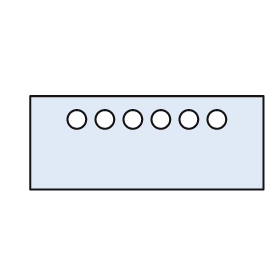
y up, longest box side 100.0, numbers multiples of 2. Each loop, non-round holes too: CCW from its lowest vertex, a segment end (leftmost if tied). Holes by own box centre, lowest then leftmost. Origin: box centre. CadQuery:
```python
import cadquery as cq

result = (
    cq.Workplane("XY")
    .moveTo(-50.0, -20.0)
    .lineTo(50.0, -20.0)
    .lineTo(50.0, 20.0)
    .lineTo(-50.0, 20.0)
    .close()
    .moveTo(-30.0, 10.0)
    .circle(4.0)
    .moveTo(-18.0, 10.0)
    .circle(4.0)
    .moveTo(-6.0, 10.0)
    .circle(4.0)
    .moveTo(6.0, 10.0)
    .circle(4.0)
    .moveTo(18.0, 10.0)
    .circle(4.0)
    .moveTo(30.0, 10.0)
    .circle(4.0)
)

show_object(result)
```